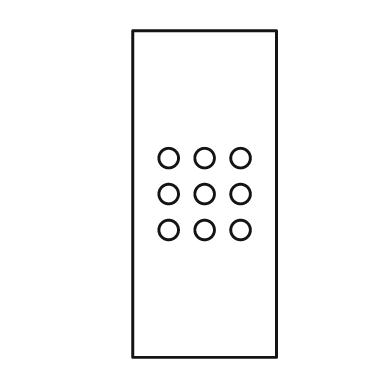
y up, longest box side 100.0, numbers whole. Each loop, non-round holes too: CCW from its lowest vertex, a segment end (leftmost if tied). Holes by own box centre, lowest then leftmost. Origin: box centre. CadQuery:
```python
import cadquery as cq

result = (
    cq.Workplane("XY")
    .moveTo(-22.0, -50.0)
    .lineTo(22.0, -50.0)
    .lineTo(22.0, 50.0)
    .lineTo(-22.0, 50.0)
    .close()
    .moveTo(-11.0, -11.0)
    .circle(3.0)
    .moveTo(0.0, -11.0)
    .circle(3.0)
    .moveTo(11.0, -11.0)
    .circle(3.0)
    .moveTo(-11.0, 0.0)
    .circle(3.0)
    .moveTo(0.0, 0.0)
    .circle(3.0)
    .moveTo(11.0, 0.0)
    .circle(3.0)
    .moveTo(-11.0, 11.0)
    .circle(3.0)
    .moveTo(0.0, 11.0)
    .circle(3.0)
    .moveTo(11.0, 11.0)
    .circle(3.0)
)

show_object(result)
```